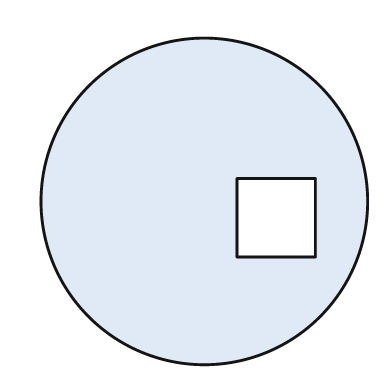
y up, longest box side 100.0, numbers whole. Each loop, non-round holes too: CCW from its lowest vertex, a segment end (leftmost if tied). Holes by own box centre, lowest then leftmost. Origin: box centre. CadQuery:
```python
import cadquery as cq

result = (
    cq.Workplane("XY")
    .moveTo(0.0, 0.0)
    .circle(50.0)
    .moveTo(10.0, -17.0)
    .lineTo(34.0, -17.0)
    .lineTo(34.0, 7.0)
    .lineTo(10.0, 7.0)
    .close()
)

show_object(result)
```